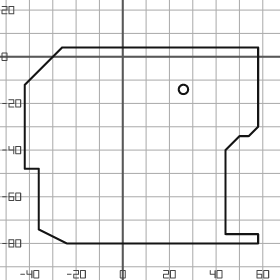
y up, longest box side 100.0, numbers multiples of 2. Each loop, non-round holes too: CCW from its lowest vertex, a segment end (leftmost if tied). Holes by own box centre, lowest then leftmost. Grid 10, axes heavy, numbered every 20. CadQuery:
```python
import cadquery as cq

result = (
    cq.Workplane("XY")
    .moveTo(-24.0, -80.0)
    .lineTo(58.0, -80.0)
    .lineTo(58.0, -76.0)
    .lineTo(44.0, -76.0)
    .lineTo(44.0, -40.0)
    .lineTo(50.0, -34.0)
    .lineTo(54.0, -34.0)
    .lineTo(58.0, -30.0)
    .lineTo(58.0, 4.0)
    .lineTo(-26.0, 4.0)
    .lineTo(-42.0, -12.0)
    .lineTo(-42.0, -48.0)
    .lineTo(-36.0, -48.0)
    .lineTo(-36.0, -74.0)
    .close()
    .moveTo(26.0, -14.0)
    .circle(2.0)
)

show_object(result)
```